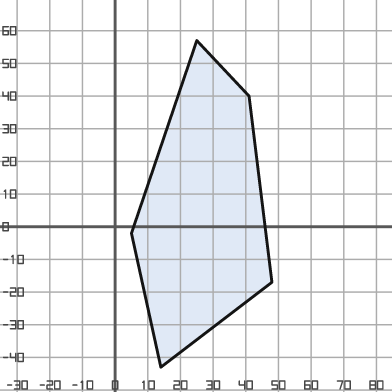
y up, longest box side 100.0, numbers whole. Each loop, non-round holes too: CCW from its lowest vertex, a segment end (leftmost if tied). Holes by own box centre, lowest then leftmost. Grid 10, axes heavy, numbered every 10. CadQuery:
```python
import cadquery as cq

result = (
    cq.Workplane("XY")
    .moveTo(14.0, -43.0)
    .lineTo(48.0, -17.0)
    .lineTo(41.0, 40.0)
    .lineTo(25.0, 57.0)
    .lineTo(5.0, -2.0)
    .close()
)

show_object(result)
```